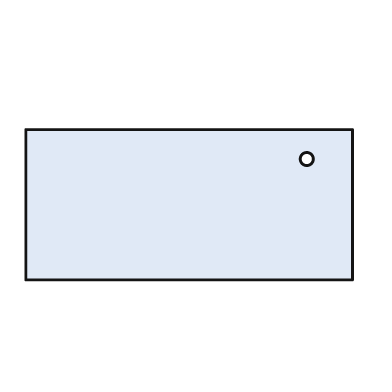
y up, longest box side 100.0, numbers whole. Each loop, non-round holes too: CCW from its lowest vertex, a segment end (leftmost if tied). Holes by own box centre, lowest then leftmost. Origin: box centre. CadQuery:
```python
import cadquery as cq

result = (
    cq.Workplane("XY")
    .moveTo(-50.0, -23.0)
    .lineTo(50.0, -23.0)
    .lineTo(50.0, 23.0)
    .lineTo(-50.0, 23.0)
    .close()
    .moveTo(36.0, 14.0)
    .circle(2.0)
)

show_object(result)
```